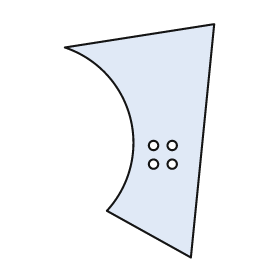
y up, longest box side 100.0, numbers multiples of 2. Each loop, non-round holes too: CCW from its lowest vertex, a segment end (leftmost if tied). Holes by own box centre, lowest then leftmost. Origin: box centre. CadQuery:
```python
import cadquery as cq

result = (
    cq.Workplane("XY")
    .moveTo(22.0, -50.0)
    .lineTo(32.0, 50.0)
    .lineTo(-32.0, 40.0)
    .threePointArc((-4.0, 10.0), (-14.0, -30.0))
    .close()
    .moveTo(6.0, -10.0)
    .circle(2.0)
    .moveTo(14.0, -10.0)
    .circle(2.0)
    .moveTo(6.0, -2.0)
    .circle(2.0)
    .moveTo(14.0, -2.0)
    .circle(2.0)
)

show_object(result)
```